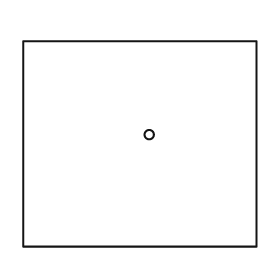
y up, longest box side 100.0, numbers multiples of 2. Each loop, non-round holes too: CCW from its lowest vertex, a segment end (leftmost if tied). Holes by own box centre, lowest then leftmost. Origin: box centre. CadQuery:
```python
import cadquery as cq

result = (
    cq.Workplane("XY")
    .moveTo(-50.0, -44.0)
    .lineTo(50.0, -44.0)
    .lineTo(50.0, 44.0)
    .lineTo(-50.0, 44.0)
    .close()
    .moveTo(4.0, 4.0)
    .circle(2.0)
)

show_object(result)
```